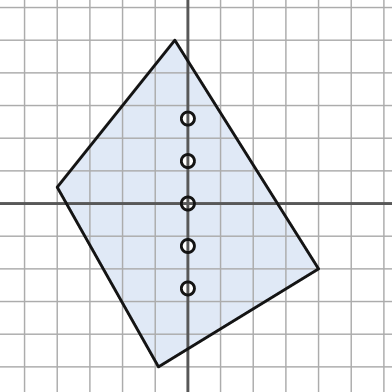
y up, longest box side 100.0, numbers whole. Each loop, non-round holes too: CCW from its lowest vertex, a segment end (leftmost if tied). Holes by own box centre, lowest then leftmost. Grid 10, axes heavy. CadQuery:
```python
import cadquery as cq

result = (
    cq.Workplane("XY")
    .moveTo(-9.0, -50.0)
    .lineTo(40.0, -20.0)
    .lineTo(-4.0, 50.0)
    .lineTo(-40.0, 5.0)
    .close()
    .moveTo(0.0, -26.0)
    .circle(2.0)
    .moveTo(0.0, -13.0)
    .circle(2.0)
    .moveTo(0.0, 0.0)
    .circle(2.0)
    .moveTo(0.0, 13.0)
    .circle(2.0)
    .moveTo(0.0, 26.0)
    .circle(2.0)
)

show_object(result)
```